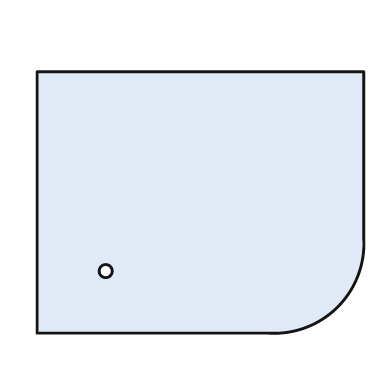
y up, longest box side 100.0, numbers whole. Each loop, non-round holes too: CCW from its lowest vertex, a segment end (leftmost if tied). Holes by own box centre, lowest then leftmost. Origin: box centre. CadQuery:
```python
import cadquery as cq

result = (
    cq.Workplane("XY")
    .moveTo(-50.0, -40.0)
    .lineTo(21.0, -40.0)
    .threePointArc((42.0, -32.0), (50.0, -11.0))
    .lineTo(50.0, 40.0)
    .lineTo(-50.0, 40.0)
    .close()
    .moveTo(-29.0, -21.0)
    .circle(2.0)
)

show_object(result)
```